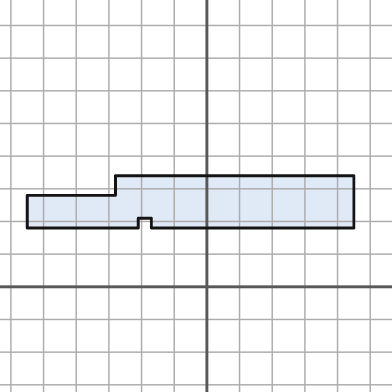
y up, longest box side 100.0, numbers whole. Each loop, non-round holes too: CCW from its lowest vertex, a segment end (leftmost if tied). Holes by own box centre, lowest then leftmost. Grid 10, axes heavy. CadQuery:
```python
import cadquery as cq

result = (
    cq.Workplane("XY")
    .moveTo(-55.0, 18.0)
    .lineTo(-21.0, 18.0)
    .lineTo(-21.0, 21.0)
    .lineTo(-17.0, 21.0)
    .lineTo(-17.0, 18.0)
    .lineTo(45.0, 18.0)
    .lineTo(45.0, 34.0)
    .lineTo(-28.0, 34.0)
    .lineTo(-28.0, 28.0)
    .lineTo(-55.0, 28.0)
    .close()
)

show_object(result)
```